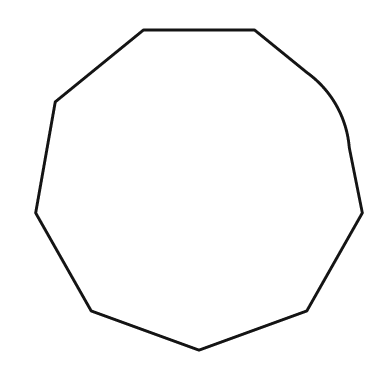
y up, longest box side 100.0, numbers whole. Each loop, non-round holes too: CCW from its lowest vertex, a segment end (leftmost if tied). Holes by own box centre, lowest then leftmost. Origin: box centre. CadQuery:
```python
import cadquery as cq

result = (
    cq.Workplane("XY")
    .moveTo(0.0, -49.0)
    .lineTo(33.0, -37.0)
    .lineTo(50.0, -7.0)
    .lineTo(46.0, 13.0)
    .threePointArc((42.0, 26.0), (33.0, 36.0))
    .lineTo(17.0, 49.0)
    .lineTo(-17.0, 49.0)
    .lineTo(-44.0, 27.0)
    .lineTo(-50.0, -7.0)
    .lineTo(-33.0, -37.0)
    .close()
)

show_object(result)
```